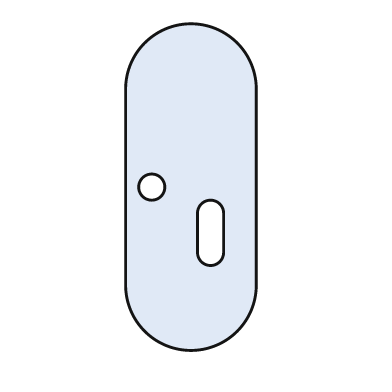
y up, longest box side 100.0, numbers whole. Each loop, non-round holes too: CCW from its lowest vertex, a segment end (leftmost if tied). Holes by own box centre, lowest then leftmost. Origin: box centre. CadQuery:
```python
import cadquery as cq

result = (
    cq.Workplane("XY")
    .moveTo(-20.0, -30.0)
    .threePointArc((0.0, -50.0), (20.0, -30.0))
    .lineTo(20.0, 30.0)
    .threePointArc((0.0, 50.0), (-20.0, 30.0))
    .close()
    .moveTo(2.0, -20.0)
    .threePointArc((6.0, -24.0), (10.0, -20.0))
    .lineTo(10.0, -8.0)
    .threePointArc((6.0, -4.0), (2.0, -8.0))
    .close()
    .moveTo(-12.0, 0.0)
    .circle(4.0)
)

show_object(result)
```